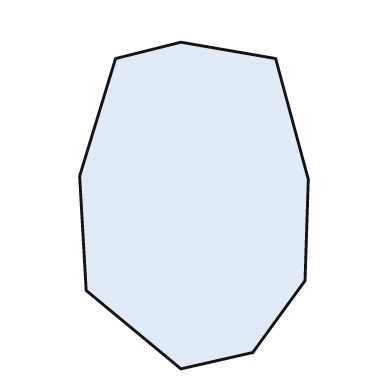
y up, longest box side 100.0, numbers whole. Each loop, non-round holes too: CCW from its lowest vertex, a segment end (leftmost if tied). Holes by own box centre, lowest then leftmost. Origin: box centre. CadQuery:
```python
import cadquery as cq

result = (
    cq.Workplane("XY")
    .moveTo(-4.0, -50.0)
    .lineTo(18.0, -45.0)
    .lineTo(34.0, -23.0)
    .lineTo(35.0, 8.0)
    .lineTo(25.0, 45.0)
    .lineTo(-4.0, 50.0)
    .lineTo(-24.0, 45.0)
    .lineTo(-35.0, 9.0)
    .lineTo(-33.0, -26.0)
    .close()
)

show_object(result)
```